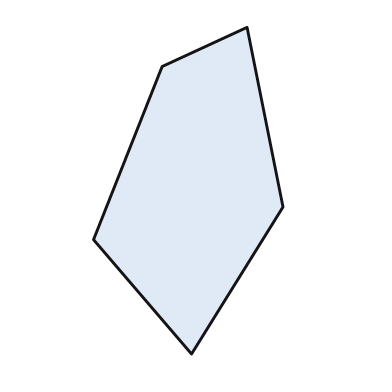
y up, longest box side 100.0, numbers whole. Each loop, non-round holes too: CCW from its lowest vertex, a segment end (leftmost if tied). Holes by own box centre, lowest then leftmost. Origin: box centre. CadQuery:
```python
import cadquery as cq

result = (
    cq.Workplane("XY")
    .moveTo(1.0, -50.0)
    .lineTo(29.0, -5.0)
    .lineTo(18.0, 50.0)
    .lineTo(-8.0, 38.0)
    .lineTo(-29.0, -15.0)
    .close()
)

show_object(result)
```